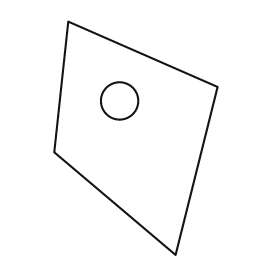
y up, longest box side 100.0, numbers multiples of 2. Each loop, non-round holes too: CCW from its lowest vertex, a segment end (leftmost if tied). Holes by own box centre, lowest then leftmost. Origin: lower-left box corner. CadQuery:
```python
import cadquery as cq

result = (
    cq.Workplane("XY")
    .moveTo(52.0, 0.0)
    .lineTo(70.0, 72.0)
    .lineTo(6.0, 100.0)
    .lineTo(0.0, 44.0)
    .close()
    .moveTo(28.0, 66.0)
    .circle(8.0)
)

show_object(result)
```